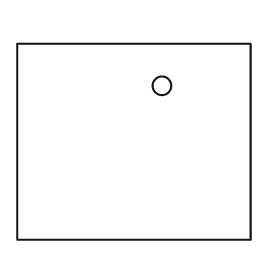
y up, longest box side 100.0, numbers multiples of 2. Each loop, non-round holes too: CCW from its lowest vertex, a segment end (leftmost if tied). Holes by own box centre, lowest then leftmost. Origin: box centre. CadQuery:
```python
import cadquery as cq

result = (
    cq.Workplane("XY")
    .moveTo(-50.0, -42.0)
    .lineTo(50.0, -42.0)
    .lineTo(50.0, 42.0)
    .lineTo(-50.0, 42.0)
    .close()
    .moveTo(12.0, 24.0)
    .circle(4.0)
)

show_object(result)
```